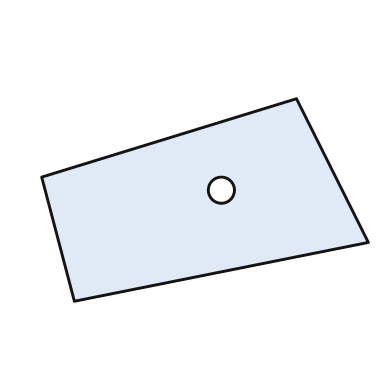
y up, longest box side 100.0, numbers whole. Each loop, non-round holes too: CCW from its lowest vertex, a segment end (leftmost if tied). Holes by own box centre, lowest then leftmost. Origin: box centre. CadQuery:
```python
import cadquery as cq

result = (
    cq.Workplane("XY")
    .moveTo(-40.0, -31.0)
    .lineTo(50.0, -13.0)
    .lineTo(28.0, 31.0)
    .lineTo(-50.0, 7.0)
    .close()
    .moveTo(5.0, 3.0)
    .circle(4.0)
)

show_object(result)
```